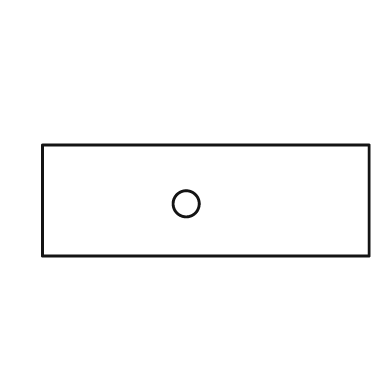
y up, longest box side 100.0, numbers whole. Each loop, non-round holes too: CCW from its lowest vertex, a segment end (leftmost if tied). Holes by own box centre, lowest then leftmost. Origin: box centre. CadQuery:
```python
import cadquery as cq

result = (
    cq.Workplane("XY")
    .moveTo(-50.0, -17.0)
    .lineTo(50.0, -17.0)
    .lineTo(50.0, 17.0)
    .lineTo(-50.0, 17.0)
    .close()
    .moveTo(-6.0, -1.0)
    .circle(4.0)
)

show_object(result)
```